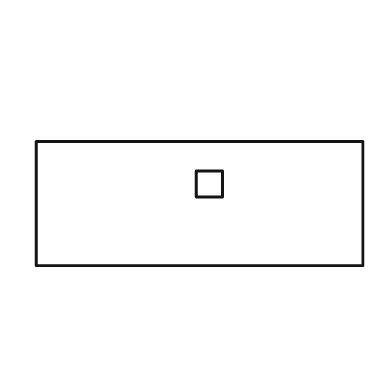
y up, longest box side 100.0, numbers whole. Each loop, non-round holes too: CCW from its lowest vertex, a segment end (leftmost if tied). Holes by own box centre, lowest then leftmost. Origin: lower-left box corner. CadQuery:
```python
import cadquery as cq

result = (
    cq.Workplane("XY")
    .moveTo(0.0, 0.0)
    .lineTo(100.0, 0.0)
    .lineTo(100.0, 38.0)
    .lineTo(0.0, 38.0)
    .close()
    .moveTo(49.0, 21.0)
    .lineTo(57.0, 21.0)
    .lineTo(57.0, 29.0)
    .lineTo(49.0, 29.0)
    .close()
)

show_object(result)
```